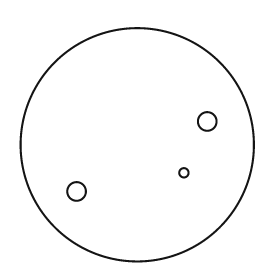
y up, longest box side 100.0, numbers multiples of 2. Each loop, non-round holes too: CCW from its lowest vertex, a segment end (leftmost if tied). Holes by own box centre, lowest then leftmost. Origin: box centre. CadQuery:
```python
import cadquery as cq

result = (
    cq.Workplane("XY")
    .moveTo(0.0, 0.0)
    .circle(50.0)
    .moveTo(-26.0, -20.0)
    .circle(4.0)
    .moveTo(20.0, -12.0)
    .circle(2.0)
    .moveTo(30.0, 10.0)
    .circle(4.0)
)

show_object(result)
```